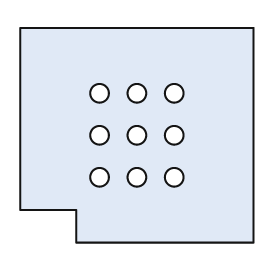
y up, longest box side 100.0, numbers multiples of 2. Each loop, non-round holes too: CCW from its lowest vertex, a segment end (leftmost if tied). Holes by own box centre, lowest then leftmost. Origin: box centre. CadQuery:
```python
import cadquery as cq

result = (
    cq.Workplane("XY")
    .moveTo(-26.0, -46.0)
    .lineTo(50.0, -46.0)
    .lineTo(50.0, 46.0)
    .lineTo(-50.0, 46.0)
    .lineTo(-50.0, -32.0)
    .lineTo(-26.0, -32.0)
    .close()
    .moveTo(-16.0, -18.0)
    .circle(4.0)
    .moveTo(0.0, -18.0)
    .circle(4.0)
    .moveTo(16.0, -18.0)
    .circle(4.0)
    .moveTo(-16.0, 0.0)
    .circle(4.0)
    .moveTo(0.0, 0.0)
    .circle(4.0)
    .moveTo(16.0, 0.0)
    .circle(4.0)
    .moveTo(-16.0, 18.0)
    .circle(4.0)
    .moveTo(0.0, 18.0)
    .circle(4.0)
    .moveTo(16.0, 18.0)
    .circle(4.0)
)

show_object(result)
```